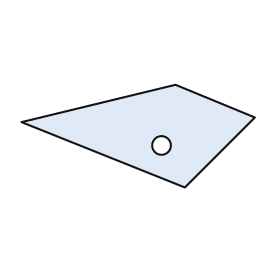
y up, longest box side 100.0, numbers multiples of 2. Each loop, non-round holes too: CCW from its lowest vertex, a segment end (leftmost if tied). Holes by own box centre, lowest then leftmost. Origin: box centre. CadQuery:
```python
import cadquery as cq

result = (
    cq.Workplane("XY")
    .moveTo(20.0, -22.0)
    .lineTo(50.0, 8.0)
    .lineTo(16.0, 22.0)
    .lineTo(-50.0, 6.0)
    .close()
    .moveTo(10.0, -4.0)
    .circle(4.0)
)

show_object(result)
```